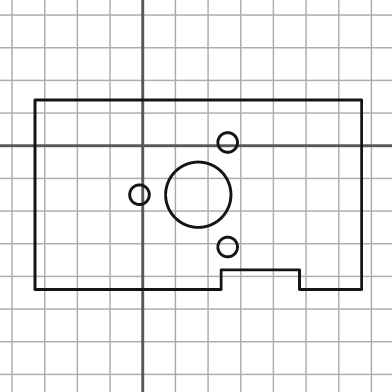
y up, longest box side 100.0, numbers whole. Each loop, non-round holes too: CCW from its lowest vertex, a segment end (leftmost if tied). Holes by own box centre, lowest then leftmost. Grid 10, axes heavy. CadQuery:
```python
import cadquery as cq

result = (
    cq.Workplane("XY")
    .moveTo(-33.0, -44.0)
    .lineTo(24.0, -44.0)
    .lineTo(24.0, -38.0)
    .lineTo(48.0, -38.0)
    .lineTo(48.0, -44.0)
    .lineTo(67.0, -44.0)
    .lineTo(67.0, 14.0)
    .lineTo(-33.0, 14.0)
    .close()
    .moveTo(26.0, -31.0)
    .circle(3.0)
    .moveTo(-1.0, -15.0)
    .circle(3.0)
    .moveTo(17.0, -15.0)
    .circle(10.0)
    .moveTo(26.0, 1.0)
    .circle(3.0)
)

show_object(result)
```